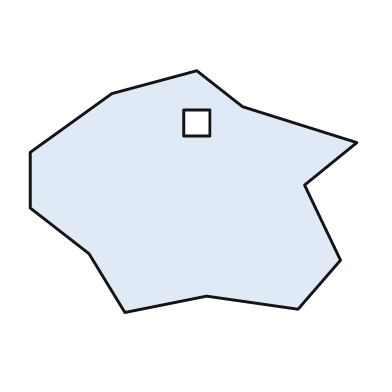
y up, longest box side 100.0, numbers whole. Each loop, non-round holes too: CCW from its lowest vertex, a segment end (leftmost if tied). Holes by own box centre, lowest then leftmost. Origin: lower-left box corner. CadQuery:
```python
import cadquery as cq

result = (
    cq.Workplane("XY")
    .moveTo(29.0, 0.0)
    .lineTo(54.0, 5.0)
    .lineTo(82.0, 1.0)
    .lineTo(95.0, 16.0)
    .lineTo(84.0, 39.0)
    .lineTo(100.0, 52.0)
    .lineTo(65.0, 63.0)
    .lineTo(51.0, 74.0)
    .lineTo(25.0, 67.0)
    .lineTo(0.0, 49.0)
    .lineTo(0.0, 32.0)
    .lineTo(18.0, 18.0)
    .close()
    .moveTo(47.0, 54.0)
    .lineTo(55.0, 54.0)
    .lineTo(55.0, 62.0)
    .lineTo(47.0, 62.0)
    .close()
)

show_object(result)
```